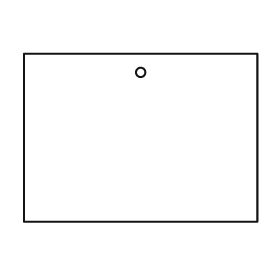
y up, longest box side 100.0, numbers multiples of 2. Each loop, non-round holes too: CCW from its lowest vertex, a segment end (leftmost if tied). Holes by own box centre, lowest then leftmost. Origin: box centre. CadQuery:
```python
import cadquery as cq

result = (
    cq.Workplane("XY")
    .moveTo(-50.0, -36.0)
    .lineTo(50.0, -36.0)
    .lineTo(50.0, 36.0)
    .lineTo(-50.0, 36.0)
    .close()
    .moveTo(0.0, 28.0)
    .circle(2.0)
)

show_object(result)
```